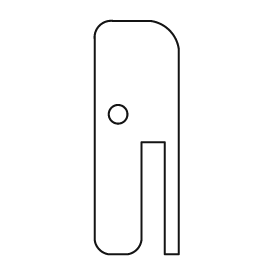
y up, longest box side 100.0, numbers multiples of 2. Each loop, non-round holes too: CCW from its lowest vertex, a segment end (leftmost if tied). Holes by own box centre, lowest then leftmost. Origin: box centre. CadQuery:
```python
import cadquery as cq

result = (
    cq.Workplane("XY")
    .moveTo(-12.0, -50.0)
    .lineTo(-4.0, -50.0)
    .threePointArc((0.0, -48.0), (2.0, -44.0))
    .lineTo(2.0, -2.0)
    .lineTo(12.0, -2.0)
    .lineTo(12.0, -50.0)
    .lineTo(18.0, -50.0)
    .lineTo(18.0, 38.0)
    .threePointArc((14.0, 46.0), (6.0, 50.0))
    .lineTo(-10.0, 50.0)
    .threePointArc((-16.0, 48.0), (-18.0, 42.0))
    .lineTo(-18.0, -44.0)
    .threePointArc((-16.0, -48.0), (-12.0, -50.0))
    .close()
    .moveTo(-8.0, 10.0)
    .circle(4.0)
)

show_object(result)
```